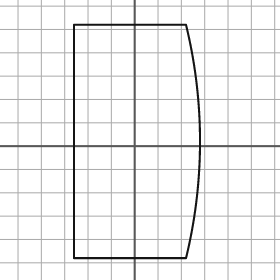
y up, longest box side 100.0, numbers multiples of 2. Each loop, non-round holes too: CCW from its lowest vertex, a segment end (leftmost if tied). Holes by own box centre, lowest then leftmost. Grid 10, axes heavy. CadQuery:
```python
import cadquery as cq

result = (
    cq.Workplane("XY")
    .moveTo(-26.0, -48.0)
    .lineTo(22.0, -48.0)
    .threePointArc((28.0, 2.0), (22.0, 52.0))
    .lineTo(-26.0, 52.0)
    .close()
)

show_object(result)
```